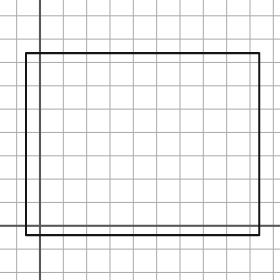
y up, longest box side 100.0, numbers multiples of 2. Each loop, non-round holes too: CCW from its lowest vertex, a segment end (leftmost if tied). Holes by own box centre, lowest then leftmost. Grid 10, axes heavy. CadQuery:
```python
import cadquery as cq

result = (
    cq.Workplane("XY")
    .moveTo(-6.0, -4.0)
    .lineTo(94.0, -4.0)
    .lineTo(94.0, 74.0)
    .lineTo(-6.0, 74.0)
    .close()
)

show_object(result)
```